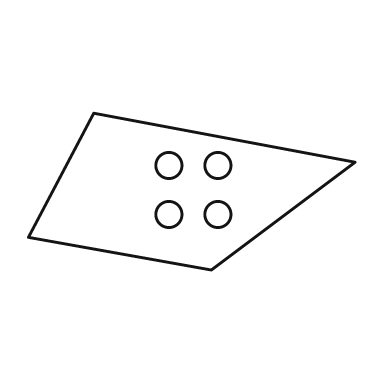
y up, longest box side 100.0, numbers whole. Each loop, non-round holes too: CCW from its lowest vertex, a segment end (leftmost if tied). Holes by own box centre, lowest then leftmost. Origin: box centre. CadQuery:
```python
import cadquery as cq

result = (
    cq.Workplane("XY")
    .moveTo(6.0, -24.0)
    .lineTo(50.0, 9.0)
    .lineTo(-30.0, 24.0)
    .lineTo(-50.0, -14.0)
    .close()
    .moveTo(-7.0, -7.0)
    .circle(4.0)
    .moveTo(8.0, -7.0)
    .circle(4.0)
    .moveTo(-7.0, 8.0)
    .circle(4.0)
    .moveTo(8.0, 8.0)
    .circle(4.0)
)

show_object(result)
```